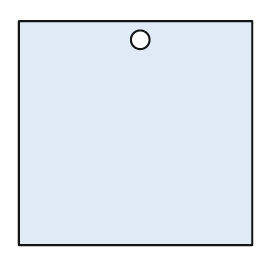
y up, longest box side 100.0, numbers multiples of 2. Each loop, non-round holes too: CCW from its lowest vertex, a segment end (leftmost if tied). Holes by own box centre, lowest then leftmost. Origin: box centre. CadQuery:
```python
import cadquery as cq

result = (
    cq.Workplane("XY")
    .moveTo(-50.0, -48.0)
    .lineTo(50.0, -48.0)
    .lineTo(50.0, 48.0)
    .lineTo(-50.0, 48.0)
    .close()
    .moveTo(2.0, 40.0)
    .circle(4.0)
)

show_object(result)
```